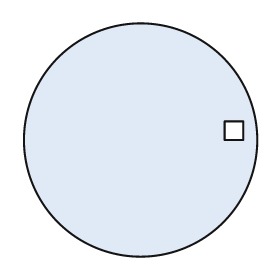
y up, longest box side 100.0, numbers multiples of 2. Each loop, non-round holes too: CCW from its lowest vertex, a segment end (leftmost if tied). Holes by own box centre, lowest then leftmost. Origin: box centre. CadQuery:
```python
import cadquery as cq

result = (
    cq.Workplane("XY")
    .moveTo(0.0, 0.0)
    .circle(50.0)
    .moveTo(36.0, 0.0)
    .lineTo(44.0, 0.0)
    .lineTo(44.0, 8.0)
    .lineTo(36.0, 8.0)
    .close()
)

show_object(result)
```